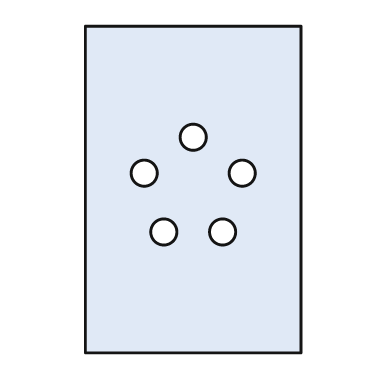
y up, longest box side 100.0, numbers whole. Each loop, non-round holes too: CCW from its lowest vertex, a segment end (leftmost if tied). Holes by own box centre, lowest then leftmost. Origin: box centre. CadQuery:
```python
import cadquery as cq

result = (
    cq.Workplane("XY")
    .moveTo(-33.0, -50.0)
    .lineTo(33.0, -50.0)
    .lineTo(33.0, 50.0)
    .lineTo(-33.0, 50.0)
    .close()
    .moveTo(-9.0, -13.0)
    .circle(4.0)
    .moveTo(9.0, -13.0)
    .circle(4.0)
    .moveTo(-15.0, 5.0)
    .circle(4.0)
    .moveTo(15.0, 5.0)
    .circle(4.0)
    .moveTo(0.0, 16.0)
    .circle(4.0)
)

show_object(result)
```